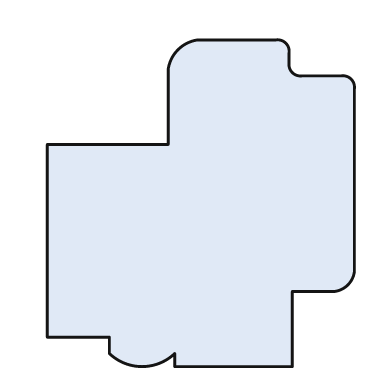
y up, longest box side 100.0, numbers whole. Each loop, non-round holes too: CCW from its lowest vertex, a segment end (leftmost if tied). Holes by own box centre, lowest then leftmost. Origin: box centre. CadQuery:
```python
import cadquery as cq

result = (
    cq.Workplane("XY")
    .moveTo(-8.0, -50.0)
    .lineTo(28.0, -50.0)
    .lineTo(28.0, -27.0)
    .lineTo(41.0, -27.0)
    .threePointArc((45.0, -25.0), (47.0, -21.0))
    .lineTo(47.0, 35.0)
    .threePointArc((46.0, 38.0), (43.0, 39.0))
    .lineTo(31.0, 39.0)
    .threePointArc((28.0, 40.0), (27.0, 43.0))
    .lineTo(27.0, 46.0)
    .threePointArc((26.0, 49.0), (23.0, 50.0))
    .lineTo(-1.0, 50.0)
    .threePointArc((-7.0, 47.0), (-10.0, 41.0))
    .lineTo(-10.0, 18.0)
    .lineTo(-47.0, 18.0)
    .lineTo(-47.0, -41.0)
    .lineTo(-28.0, -41.0)
    .lineTo(-28.0, -46.0)
    .threePointArc((-18.0, -50.0), (-8.0, -46.0))
    .close()
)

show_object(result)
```